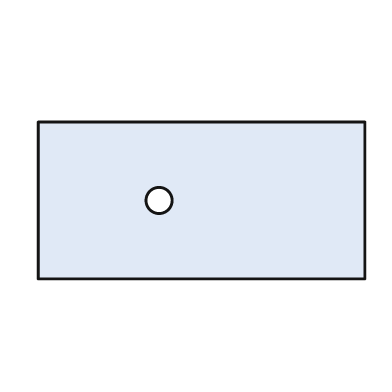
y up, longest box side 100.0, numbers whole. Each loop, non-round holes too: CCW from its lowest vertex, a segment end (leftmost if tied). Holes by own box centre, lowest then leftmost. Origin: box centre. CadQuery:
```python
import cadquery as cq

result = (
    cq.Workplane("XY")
    .moveTo(-50.0, -24.0)
    .lineTo(50.0, -24.0)
    .lineTo(50.0, 24.0)
    .lineTo(-50.0, 24.0)
    .close()
    .moveTo(-13.0, 0.0)
    .circle(4.0)
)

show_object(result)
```